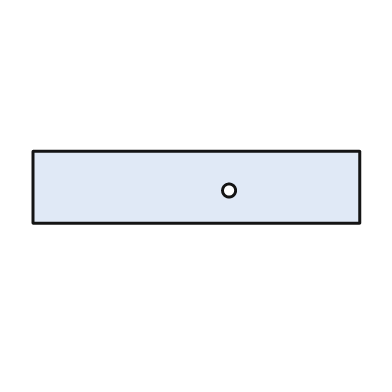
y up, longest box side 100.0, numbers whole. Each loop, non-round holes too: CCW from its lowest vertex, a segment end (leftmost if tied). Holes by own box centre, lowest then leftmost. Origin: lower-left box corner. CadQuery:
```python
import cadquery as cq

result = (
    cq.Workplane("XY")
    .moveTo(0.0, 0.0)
    .lineTo(100.0, 0.0)
    .lineTo(100.0, 22.0)
    .lineTo(0.0, 22.0)
    .close()
    .moveTo(60.0, 10.0)
    .circle(2.0)
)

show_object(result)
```